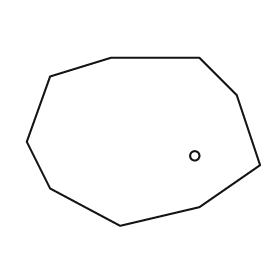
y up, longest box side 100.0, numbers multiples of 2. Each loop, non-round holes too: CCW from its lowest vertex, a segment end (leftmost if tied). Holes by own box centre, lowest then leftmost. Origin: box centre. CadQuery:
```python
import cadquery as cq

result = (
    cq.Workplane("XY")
    .moveTo(-10.0, -36.0)
    .lineTo(24.0, -28.0)
    .lineTo(50.0, -10.0)
    .lineTo(40.0, 20.0)
    .lineTo(24.0, 36.0)
    .lineTo(-14.0, 36.0)
    .lineTo(-40.0, 28.0)
    .lineTo(-50.0, 0.0)
    .lineTo(-40.0, -20.0)
    .close()
    .moveTo(22.0, -6.0)
    .circle(2.0)
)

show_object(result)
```